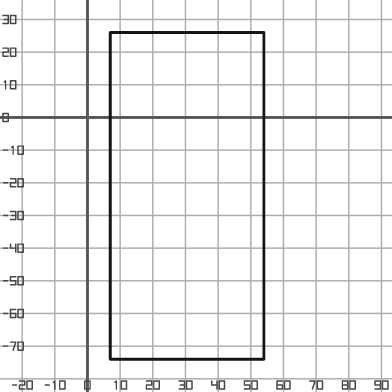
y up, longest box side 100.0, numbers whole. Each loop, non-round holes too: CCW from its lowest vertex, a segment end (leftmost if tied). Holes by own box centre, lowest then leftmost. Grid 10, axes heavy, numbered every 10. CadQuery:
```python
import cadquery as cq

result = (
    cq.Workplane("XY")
    .moveTo(7.0, -74.0)
    .lineTo(54.0, -74.0)
    .lineTo(54.0, 26.0)
    .lineTo(7.0, 26.0)
    .close()
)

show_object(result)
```